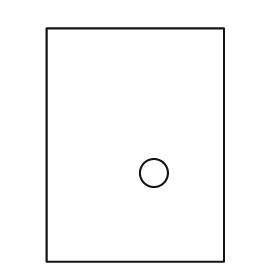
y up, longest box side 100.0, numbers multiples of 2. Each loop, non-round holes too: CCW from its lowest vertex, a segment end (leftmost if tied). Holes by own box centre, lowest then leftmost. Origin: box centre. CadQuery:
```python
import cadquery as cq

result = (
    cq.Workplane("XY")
    .moveTo(-38.0, -50.0)
    .lineTo(38.0, -50.0)
    .lineTo(38.0, 50.0)
    .lineTo(-38.0, 50.0)
    .close()
    .moveTo(8.0, -12.0)
    .circle(6.0)
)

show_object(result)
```